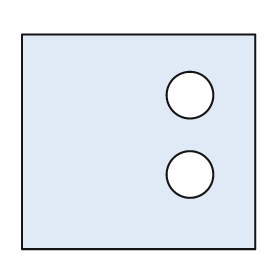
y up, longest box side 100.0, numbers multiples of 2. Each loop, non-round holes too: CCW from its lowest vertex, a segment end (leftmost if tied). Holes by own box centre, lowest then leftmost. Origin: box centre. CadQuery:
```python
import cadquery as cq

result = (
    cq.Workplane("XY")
    .moveTo(-50.0, -46.0)
    .lineTo(50.0, -46.0)
    .lineTo(50.0, 46.0)
    .lineTo(-50.0, 46.0)
    .close()
    .moveTo(22.0, -14.0)
    .circle(10.0)
    .moveTo(22.0, 20.0)
    .circle(10.0)
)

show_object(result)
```